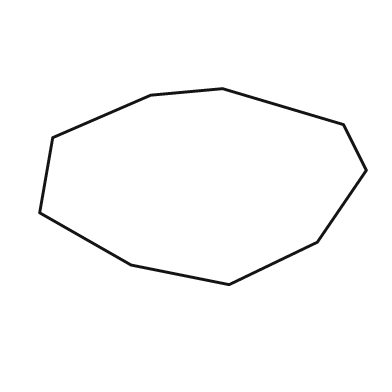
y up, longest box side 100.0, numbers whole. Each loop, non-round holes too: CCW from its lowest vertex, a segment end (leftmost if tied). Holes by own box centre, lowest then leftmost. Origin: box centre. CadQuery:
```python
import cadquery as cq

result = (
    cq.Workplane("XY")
    .moveTo(8.0, -30.0)
    .lineTo(35.0, -17.0)
    .lineTo(50.0, 5.0)
    .lineTo(43.0, 19.0)
    .lineTo(6.0, 30.0)
    .lineTo(-16.0, 28.0)
    .lineTo(-46.0, 15.0)
    .lineTo(-50.0, -8.0)
    .lineTo(-22.0, -24.0)
    .close()
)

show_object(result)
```